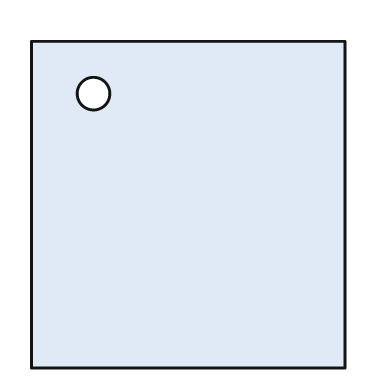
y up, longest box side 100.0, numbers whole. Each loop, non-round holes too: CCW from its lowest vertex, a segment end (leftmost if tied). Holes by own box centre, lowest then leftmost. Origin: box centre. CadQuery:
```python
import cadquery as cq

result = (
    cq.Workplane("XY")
    .moveTo(-48.0, -50.0)
    .lineTo(48.0, -50.0)
    .lineTo(48.0, 50.0)
    .lineTo(-48.0, 50.0)
    .close()
    .moveTo(-29.0, 34.0)
    .circle(5.0)
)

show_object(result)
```